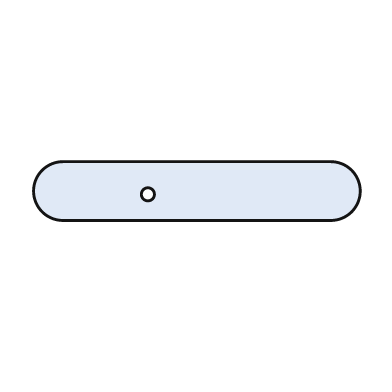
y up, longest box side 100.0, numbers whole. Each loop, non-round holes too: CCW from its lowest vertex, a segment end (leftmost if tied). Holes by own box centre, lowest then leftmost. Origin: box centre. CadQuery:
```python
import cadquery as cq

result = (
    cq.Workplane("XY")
    .moveTo(-41.0, -9.0)
    .lineTo(41.0, -9.0)
    .threePointArc((50.0, 0.0), (41.0, 9.0))
    .lineTo(-41.0, 9.0)
    .threePointArc((-50.0, 0.0), (-41.0, -9.0))
    .close()
    .moveTo(-15.0, -1.0)
    .circle(2.0)
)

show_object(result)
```